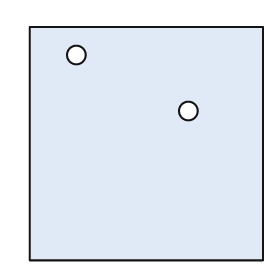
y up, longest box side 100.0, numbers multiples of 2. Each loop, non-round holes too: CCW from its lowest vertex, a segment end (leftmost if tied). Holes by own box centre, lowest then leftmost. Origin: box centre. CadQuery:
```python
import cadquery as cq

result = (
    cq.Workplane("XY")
    .moveTo(-50.0, -50.0)
    .lineTo(50.0, -50.0)
    .lineTo(50.0, 50.0)
    .lineTo(-50.0, 50.0)
    .close()
    .moveTo(18.0, 14.0)
    .circle(4.0)
    .moveTo(-30.0, 38.0)
    .circle(4.0)
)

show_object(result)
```